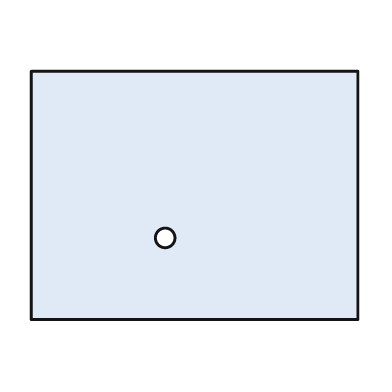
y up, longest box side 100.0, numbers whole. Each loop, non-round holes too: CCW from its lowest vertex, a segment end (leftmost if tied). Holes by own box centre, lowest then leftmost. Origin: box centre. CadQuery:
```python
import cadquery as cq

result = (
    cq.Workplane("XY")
    .moveTo(-50.0, -38.0)
    .lineTo(50.0, -38.0)
    .lineTo(50.0, 38.0)
    .lineTo(-50.0, 38.0)
    .close()
    .moveTo(-9.0, -13.0)
    .circle(3.0)
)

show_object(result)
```